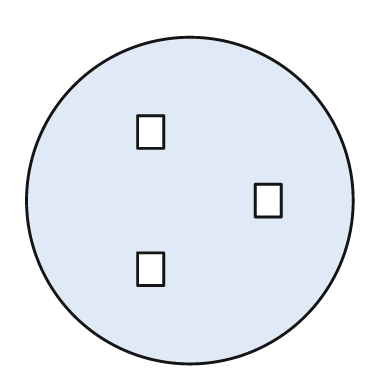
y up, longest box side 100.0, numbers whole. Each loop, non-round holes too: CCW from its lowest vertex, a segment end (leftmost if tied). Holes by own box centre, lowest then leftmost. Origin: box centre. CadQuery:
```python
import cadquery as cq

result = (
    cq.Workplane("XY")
    .moveTo(0.0, 0.0)
    .circle(50.0)
    .moveTo(-16.0, -26.0)
    .lineTo(-8.0, -26.0)
    .lineTo(-8.0, -16.0)
    .lineTo(-16.0, -16.0)
    .close()
    .moveTo(20.0, -5.0)
    .lineTo(28.0, -5.0)
    .lineTo(28.0, 5.0)
    .lineTo(20.0, 5.0)
    .close()
    .moveTo(-16.0, 16.0)
    .lineTo(-8.0, 16.0)
    .lineTo(-8.0, 26.0)
    .lineTo(-16.0, 26.0)
    .close()
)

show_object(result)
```